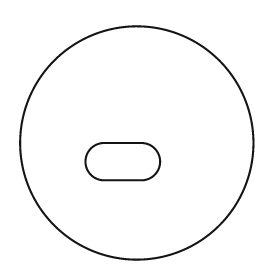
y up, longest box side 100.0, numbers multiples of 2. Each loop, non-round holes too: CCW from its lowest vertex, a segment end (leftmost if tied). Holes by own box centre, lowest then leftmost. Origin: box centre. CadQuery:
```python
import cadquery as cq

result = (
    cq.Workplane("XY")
    .moveTo(0.0, 0.0)
    .circle(50.0)
    .moveTo(-14.0, -16.0)
    .lineTo(2.0, -16.0)
    .threePointArc((10.0, -8.0), (2.0, 0.0))
    .lineTo(-14.0, 0.0)
    .threePointArc((-22.0, -8.0), (-14.0, -16.0))
    .close()
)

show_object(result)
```